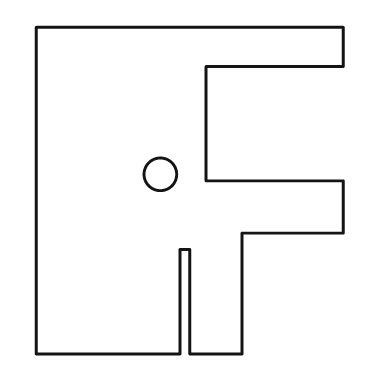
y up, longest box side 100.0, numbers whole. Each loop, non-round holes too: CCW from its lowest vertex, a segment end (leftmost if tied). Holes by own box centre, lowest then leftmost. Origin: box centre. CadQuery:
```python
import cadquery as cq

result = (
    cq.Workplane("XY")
    .moveTo(-47.0, -50.0)
    .lineTo(-3.0, -50.0)
    .lineTo(-3.0, -18.0)
    .lineTo(0.0, -18.0)
    .lineTo(0.0, -50.0)
    .lineTo(16.0, -50.0)
    .lineTo(16.0, -13.0)
    .lineTo(47.0, -13.0)
    .lineTo(47.0, 3.0)
    .lineTo(5.0, 3.0)
    .lineTo(5.0, 38.0)
    .lineTo(47.0, 38.0)
    .lineTo(47.0, 50.0)
    .lineTo(-47.0, 50.0)
    .close()
    .moveTo(-9.0, 5.0)
    .circle(5.0)
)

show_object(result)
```